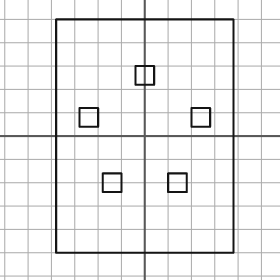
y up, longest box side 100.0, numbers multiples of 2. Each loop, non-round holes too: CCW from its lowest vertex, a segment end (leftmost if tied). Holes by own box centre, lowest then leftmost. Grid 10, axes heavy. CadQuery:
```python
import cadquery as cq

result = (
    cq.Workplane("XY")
    .moveTo(-38.0, -50.0)
    .lineTo(38.0, -50.0)
    .lineTo(38.0, 50.0)
    .lineTo(-38.0, 50.0)
    .close()
    .moveTo(-18.0, -24.0)
    .lineTo(-10.0, -24.0)
    .lineTo(-10.0, -16.0)
    .lineTo(-18.0, -16.0)
    .close()
    .moveTo(10.0, -24.0)
    .lineTo(18.0, -24.0)
    .lineTo(18.0, -16.0)
    .lineTo(10.0, -16.0)
    .close()
    .moveTo(-28.0, 4.0)
    .lineTo(-20.0, 4.0)
    .lineTo(-20.0, 12.0)
    .lineTo(-28.0, 12.0)
    .close()
    .moveTo(20.0, 4.0)
    .lineTo(28.0, 4.0)
    .lineTo(28.0, 12.0)
    .lineTo(20.0, 12.0)
    .close()
    .moveTo(-4.0, 22.0)
    .lineTo(4.0, 22.0)
    .lineTo(4.0, 30.0)
    .lineTo(-4.0, 30.0)
    .close()
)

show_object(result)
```